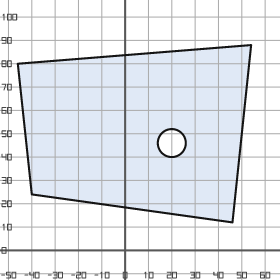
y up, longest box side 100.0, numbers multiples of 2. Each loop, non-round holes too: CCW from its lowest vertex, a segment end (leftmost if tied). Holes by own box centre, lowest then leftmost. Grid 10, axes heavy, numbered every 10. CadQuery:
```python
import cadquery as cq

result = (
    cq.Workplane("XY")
    .moveTo(46.0, 12.0)
    .lineTo(54.0, 88.0)
    .lineTo(-46.0, 80.0)
    .lineTo(-40.0, 24.0)
    .close()
    .moveTo(20.0, 46.0)
    .circle(6.0)
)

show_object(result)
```